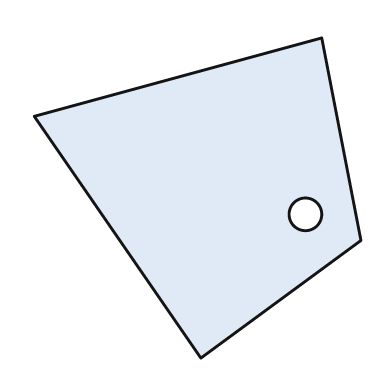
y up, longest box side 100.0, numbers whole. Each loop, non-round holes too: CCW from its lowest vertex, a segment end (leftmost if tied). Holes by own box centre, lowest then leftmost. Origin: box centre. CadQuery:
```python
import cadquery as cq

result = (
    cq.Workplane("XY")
    .moveTo(1.0, -49.0)
    .lineTo(50.0, -13.0)
    .lineTo(38.0, 49.0)
    .lineTo(-50.0, 25.0)
    .close()
    .moveTo(33.0, -5.0)
    .circle(5.0)
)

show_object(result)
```